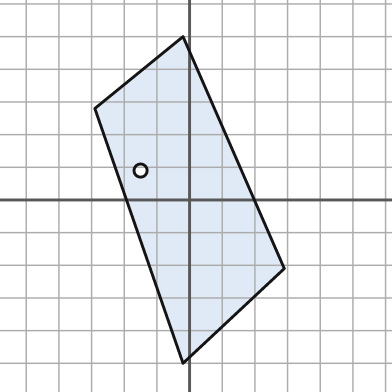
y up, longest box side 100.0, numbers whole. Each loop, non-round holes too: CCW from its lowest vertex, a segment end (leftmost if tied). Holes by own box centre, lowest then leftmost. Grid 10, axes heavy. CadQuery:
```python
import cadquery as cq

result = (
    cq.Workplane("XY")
    .moveTo(-2.0, -50.0)
    .lineTo(29.0, -21.0)
    .lineTo(-2.0, 50.0)
    .lineTo(-29.0, 28.0)
    .close()
    .moveTo(-15.0, 9.0)
    .circle(2.0)
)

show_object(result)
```